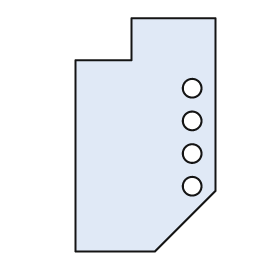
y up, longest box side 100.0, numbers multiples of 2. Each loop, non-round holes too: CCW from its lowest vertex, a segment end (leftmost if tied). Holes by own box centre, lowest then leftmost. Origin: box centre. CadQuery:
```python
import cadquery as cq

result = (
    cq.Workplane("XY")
    .moveTo(-30.0, -50.0)
    .lineTo(4.0, -50.0)
    .lineTo(30.0, -24.0)
    .lineTo(30.0, 50.0)
    .lineTo(-6.0, 50.0)
    .lineTo(-6.0, 32.0)
    .lineTo(-30.0, 32.0)
    .close()
    .moveTo(20.0, -22.0)
    .circle(4.0)
    .moveTo(20.0, -8.0)
    .circle(4.0)
    .moveTo(20.0, 6.0)
    .circle(4.0)
    .moveTo(20.0, 20.0)
    .circle(4.0)
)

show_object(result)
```